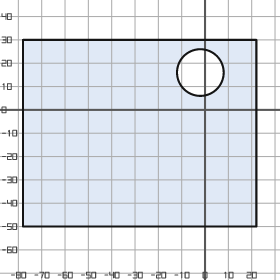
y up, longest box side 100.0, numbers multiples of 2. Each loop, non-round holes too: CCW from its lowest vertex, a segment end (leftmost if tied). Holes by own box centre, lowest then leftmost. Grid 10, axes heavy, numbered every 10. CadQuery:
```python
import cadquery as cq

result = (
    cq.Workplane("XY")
    .moveTo(-78.0, -50.0)
    .lineTo(22.0, -50.0)
    .lineTo(22.0, 30.0)
    .lineTo(-78.0, 30.0)
    .close()
    .moveTo(-2.0, 16.0)
    .circle(10.0)
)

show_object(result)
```